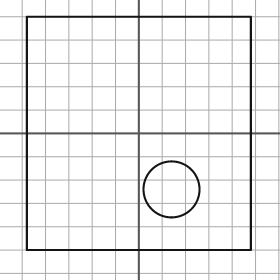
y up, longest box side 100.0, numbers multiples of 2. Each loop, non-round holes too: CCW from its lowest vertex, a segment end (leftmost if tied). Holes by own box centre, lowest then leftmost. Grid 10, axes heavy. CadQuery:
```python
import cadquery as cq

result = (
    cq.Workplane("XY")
    .moveTo(-48.0, -50.0)
    .lineTo(48.0, -50.0)
    .lineTo(48.0, 50.0)
    .lineTo(-48.0, 50.0)
    .close()
    .moveTo(14.0, -24.0)
    .circle(12.0)
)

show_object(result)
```